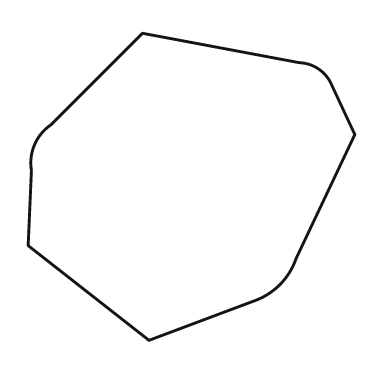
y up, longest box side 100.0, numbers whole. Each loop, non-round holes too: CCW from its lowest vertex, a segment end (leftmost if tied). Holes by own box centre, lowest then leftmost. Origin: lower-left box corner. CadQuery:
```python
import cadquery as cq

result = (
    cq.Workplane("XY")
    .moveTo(37.0, 0.0)
    .lineTo(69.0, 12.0)
    .threePointArc((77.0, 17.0), (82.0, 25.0))
    .lineTo(100.0, 63.0)
    .lineTo(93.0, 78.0)
    .threePointArc((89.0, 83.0), (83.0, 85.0))
    .lineTo(35.0, 94.0)
    .lineTo(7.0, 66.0)
    .threePointArc((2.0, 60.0), (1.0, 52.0))
    .lineTo(0.0, 29.0)
    .close()
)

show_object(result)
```